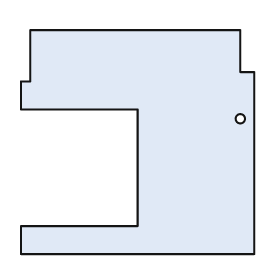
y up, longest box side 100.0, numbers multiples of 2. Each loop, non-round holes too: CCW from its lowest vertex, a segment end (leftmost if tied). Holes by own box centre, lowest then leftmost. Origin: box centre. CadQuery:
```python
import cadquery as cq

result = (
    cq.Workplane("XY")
    .moveTo(-50.0, -48.0)
    .lineTo(50.0, -48.0)
    .lineTo(50.0, 30.0)
    .lineTo(44.0, 30.0)
    .lineTo(44.0, 48.0)
    .lineTo(-46.0, 48.0)
    .lineTo(-46.0, 26.0)
    .lineTo(-50.0, 26.0)
    .lineTo(-50.0, 14.0)
    .lineTo(0.0, 14.0)
    .lineTo(0.0, -36.0)
    .lineTo(-50.0, -36.0)
    .close()
    .moveTo(44.0, 10.0)
    .circle(2.0)
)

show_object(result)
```